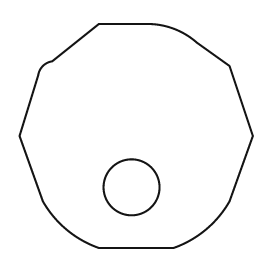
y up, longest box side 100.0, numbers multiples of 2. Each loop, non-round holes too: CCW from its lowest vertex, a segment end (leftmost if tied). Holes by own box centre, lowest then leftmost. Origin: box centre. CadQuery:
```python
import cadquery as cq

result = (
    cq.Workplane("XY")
    .moveTo(-16.0, -48.0)
    .lineTo(16.0, -48.0)
    .threePointArc((30.0, -40.0), (40.0, -28.0))
    .lineTo(50.0, 0.0)
    .lineTo(40.0, 30.0)
    .lineTo(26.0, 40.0)
    .threePointArc((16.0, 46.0), (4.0, 48.0))
    .lineTo(-16.0, 48.0)
    .lineTo(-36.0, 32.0)
    .threePointArc((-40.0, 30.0), (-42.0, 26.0))
    .lineTo(-50.0, 0.0)
    .lineTo(-40.0, -28.0)
    .threePointArc((-30.0, -40.0), (-16.0, -48.0))
    .close()
    .moveTo(-2.0, -22.0)
    .circle(12.0)
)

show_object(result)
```